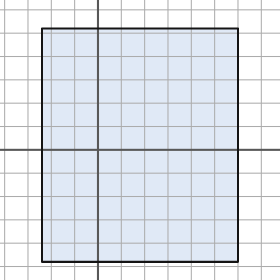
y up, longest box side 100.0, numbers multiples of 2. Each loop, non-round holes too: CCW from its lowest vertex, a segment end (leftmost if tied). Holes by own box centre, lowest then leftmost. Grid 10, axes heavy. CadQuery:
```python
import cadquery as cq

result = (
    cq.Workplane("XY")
    .moveTo(-24.0, -48.0)
    .lineTo(60.0, -48.0)
    .lineTo(60.0, 52.0)
    .lineTo(-24.0, 52.0)
    .close()
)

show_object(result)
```